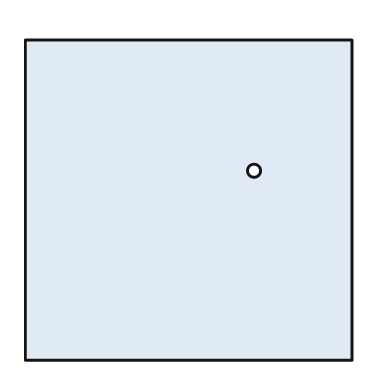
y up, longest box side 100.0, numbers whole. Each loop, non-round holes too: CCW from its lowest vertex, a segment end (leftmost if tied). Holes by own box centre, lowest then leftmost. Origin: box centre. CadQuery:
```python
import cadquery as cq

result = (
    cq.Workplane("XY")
    .moveTo(-50.0, -49.0)
    .lineTo(50.0, -49.0)
    .lineTo(50.0, 49.0)
    .lineTo(-50.0, 49.0)
    .close()
    .moveTo(20.0, 9.0)
    .circle(2.0)
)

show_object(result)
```